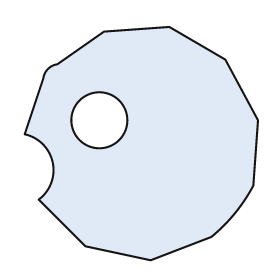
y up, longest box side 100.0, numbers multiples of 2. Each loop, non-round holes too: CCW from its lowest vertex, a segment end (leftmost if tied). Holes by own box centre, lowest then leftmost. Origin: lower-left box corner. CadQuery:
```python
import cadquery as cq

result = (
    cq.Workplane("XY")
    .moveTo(54.0, 0.0)
    .lineTo(80.0, 10.0)
    .threePointArc((90.0, 20.0), (98.0, 32.0))
    .lineTo(100.0, 60.0)
    .lineTo(86.0, 86.0)
    .lineTo(62.0, 100.0)
    .lineTo(34.0, 98.0)
    .lineTo(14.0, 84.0)
    .threePointArc((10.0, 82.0), (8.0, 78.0))
    .lineTo(0.0, 54.0)
    .threePointArc((12.0, 42.0), (6.0, 26.0))
    .lineTo(26.0, 6.0)
    .close()
    .moveTo(32.0, 60.0)
    .circle(12.0)
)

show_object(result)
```